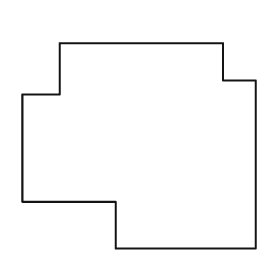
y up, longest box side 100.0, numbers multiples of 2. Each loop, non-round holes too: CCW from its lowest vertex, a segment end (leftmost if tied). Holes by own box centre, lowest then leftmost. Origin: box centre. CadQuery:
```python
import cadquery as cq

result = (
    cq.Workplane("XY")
    .moveTo(-10.0, -44.0)
    .lineTo(50.0, -44.0)
    .lineTo(50.0, 28.0)
    .lineTo(36.0, 28.0)
    .lineTo(36.0, 44.0)
    .lineTo(-34.0, 44.0)
    .lineTo(-34.0, 22.0)
    .lineTo(-50.0, 22.0)
    .lineTo(-50.0, -24.0)
    .lineTo(-10.0, -24.0)
    .close()
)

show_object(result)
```